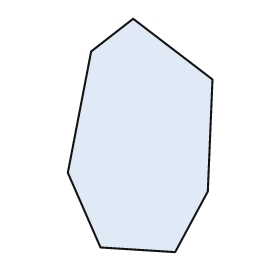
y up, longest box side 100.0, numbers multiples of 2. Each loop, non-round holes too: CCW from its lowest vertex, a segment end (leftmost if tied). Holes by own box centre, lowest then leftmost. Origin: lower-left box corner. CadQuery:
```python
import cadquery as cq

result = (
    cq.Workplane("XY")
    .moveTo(46.0, 0.0)
    .lineTo(60.0, 26.0)
    .lineTo(62.0, 74.0)
    .lineTo(28.0, 100.0)
    .lineTo(10.0, 86.0)
    .lineTo(0.0, 34.0)
    .lineTo(14.0, 2.0)
    .close()
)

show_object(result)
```